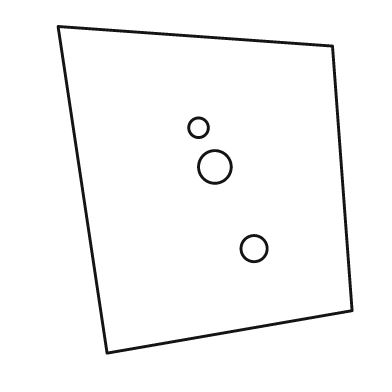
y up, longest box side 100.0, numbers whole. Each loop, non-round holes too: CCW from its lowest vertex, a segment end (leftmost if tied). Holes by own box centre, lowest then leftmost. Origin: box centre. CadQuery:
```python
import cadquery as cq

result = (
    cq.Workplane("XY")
    .moveTo(-30.0, -50.0)
    .lineTo(45.0, -37.0)
    .lineTo(39.0, 44.0)
    .lineTo(-45.0, 50.0)
    .close()
    .moveTo(15.0, -18.0)
    .circle(4.0)
    .moveTo(3.0, 7.0)
    .circle(5.0)
    .moveTo(-2.0, 19.0)
    .circle(3.0)
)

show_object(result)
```